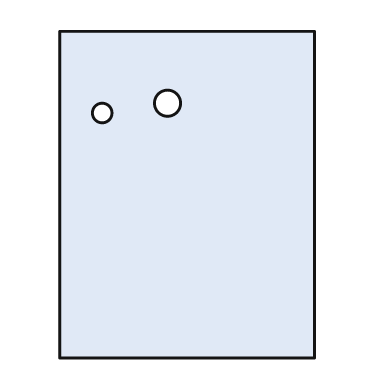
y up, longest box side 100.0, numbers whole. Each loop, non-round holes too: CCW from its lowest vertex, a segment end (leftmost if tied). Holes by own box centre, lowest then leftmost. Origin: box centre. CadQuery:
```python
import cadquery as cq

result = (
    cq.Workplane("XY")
    .moveTo(-39.0, -50.0)
    .lineTo(39.0, -50.0)
    .lineTo(39.0, 50.0)
    .lineTo(-39.0, 50.0)
    .close()
    .moveTo(-26.0, 25.0)
    .circle(3.0)
    .moveTo(-6.0, 28.0)
    .circle(4.0)
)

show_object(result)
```